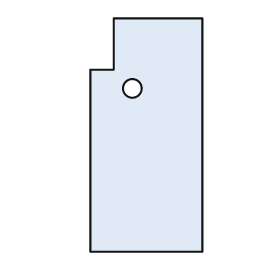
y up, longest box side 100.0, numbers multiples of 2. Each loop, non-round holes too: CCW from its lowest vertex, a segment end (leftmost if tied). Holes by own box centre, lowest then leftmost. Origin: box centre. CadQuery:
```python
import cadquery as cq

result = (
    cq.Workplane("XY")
    .moveTo(-24.0, -50.0)
    .lineTo(24.0, -50.0)
    .lineTo(24.0, 50.0)
    .lineTo(-14.0, 50.0)
    .lineTo(-14.0, 28.0)
    .lineTo(-24.0, 28.0)
    .close()
    .moveTo(-6.0, 20.0)
    .circle(4.0)
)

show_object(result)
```